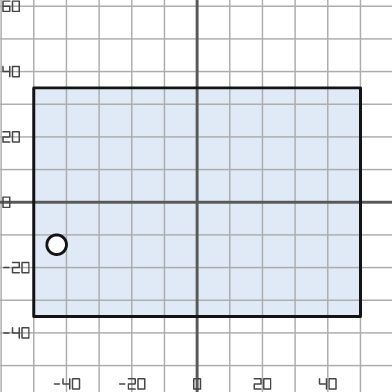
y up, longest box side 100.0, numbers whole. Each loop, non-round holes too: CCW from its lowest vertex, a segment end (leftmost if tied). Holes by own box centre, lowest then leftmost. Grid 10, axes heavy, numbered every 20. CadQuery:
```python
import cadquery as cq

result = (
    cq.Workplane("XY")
    .moveTo(-50.0, -35.0)
    .lineTo(50.0, -35.0)
    .lineTo(50.0, 35.0)
    .lineTo(-50.0, 35.0)
    .close()
    .moveTo(-43.0, -13.0)
    .circle(3.0)
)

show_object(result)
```